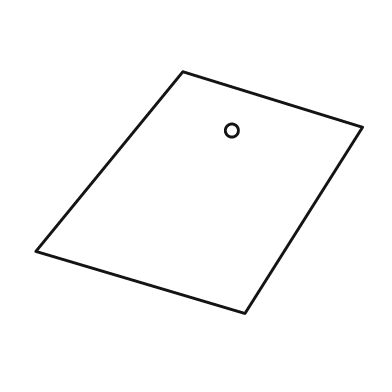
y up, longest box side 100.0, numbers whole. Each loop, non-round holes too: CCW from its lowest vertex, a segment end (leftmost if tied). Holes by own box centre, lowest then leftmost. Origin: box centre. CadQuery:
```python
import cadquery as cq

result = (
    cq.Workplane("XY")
    .moveTo(14.0, -37.0)
    .lineTo(50.0, 20.0)
    .lineTo(-5.0, 37.0)
    .lineTo(-50.0, -18.0)
    .close()
    .moveTo(10.0, 19.0)
    .circle(2.0)
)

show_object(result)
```